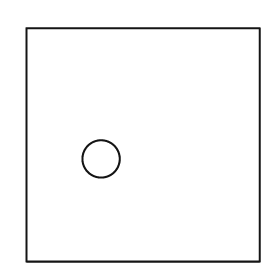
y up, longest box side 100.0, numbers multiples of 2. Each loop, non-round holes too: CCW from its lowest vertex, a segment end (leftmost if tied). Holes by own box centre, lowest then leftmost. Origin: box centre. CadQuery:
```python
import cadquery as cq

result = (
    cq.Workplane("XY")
    .moveTo(-50.0, -50.0)
    .lineTo(50.0, -50.0)
    .lineTo(50.0, 50.0)
    .lineTo(-50.0, 50.0)
    .close()
    .moveTo(-18.0, -6.0)
    .circle(8.0)
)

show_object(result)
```